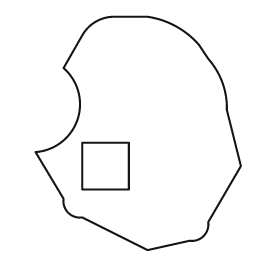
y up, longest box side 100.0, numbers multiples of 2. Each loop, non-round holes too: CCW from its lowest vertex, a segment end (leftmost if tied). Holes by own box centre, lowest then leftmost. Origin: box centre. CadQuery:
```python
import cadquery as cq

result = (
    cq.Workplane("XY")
    .moveTo(4.0, -50.0)
    .lineTo(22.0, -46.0)
    .threePointArc((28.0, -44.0), (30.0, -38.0))
    .lineTo(44.0, -14.0)
    .lineTo(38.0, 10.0)
    .threePointArc((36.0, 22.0), (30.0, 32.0))
    .lineTo(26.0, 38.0)
    .threePointArc((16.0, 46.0), (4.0, 50.0))
    .lineTo(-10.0, 50.0)
    .threePointArc((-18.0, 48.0), (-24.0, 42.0))
    .lineTo(-32.0, 28.0)
    .threePointArc((-26.0, 6.0), (-44.0, -8.0))
    .lineTo(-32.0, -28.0)
    .threePointArc((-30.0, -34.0), (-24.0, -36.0))
    .close()
    .moveTo(-24.0, -24.0)
    .lineTo(-4.0, -24.0)
    .lineTo(-4.0, -4.0)
    .lineTo(-24.0, -4.0)
    .close()
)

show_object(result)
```